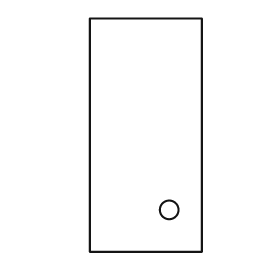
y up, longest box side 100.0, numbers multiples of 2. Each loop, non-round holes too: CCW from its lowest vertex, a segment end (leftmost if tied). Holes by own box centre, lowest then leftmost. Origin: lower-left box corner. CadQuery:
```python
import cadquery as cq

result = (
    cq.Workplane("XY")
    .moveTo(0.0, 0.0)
    .lineTo(48.0, 0.0)
    .lineTo(48.0, 100.0)
    .lineTo(0.0, 100.0)
    .close()
    .moveTo(34.0, 18.0)
    .circle(4.0)
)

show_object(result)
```